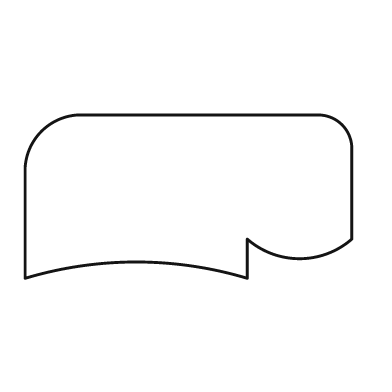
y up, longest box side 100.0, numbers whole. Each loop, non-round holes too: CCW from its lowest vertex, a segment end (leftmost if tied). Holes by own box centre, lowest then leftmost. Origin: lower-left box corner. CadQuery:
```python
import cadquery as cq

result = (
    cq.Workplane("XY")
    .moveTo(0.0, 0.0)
    .threePointArc((34.0, 5.0), (68.0, 0.0))
    .lineTo(68.0, 12.0)
    .threePointArc((84.0, 6.0), (100.0, 12.0))
    .lineTo(100.0, 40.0)
    .threePointArc((97.0, 47.0), (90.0, 50.0))
    .lineTo(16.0, 50.0)
    .threePointArc((5.0, 45.0), (0.0, 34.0))
    .close()
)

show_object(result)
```